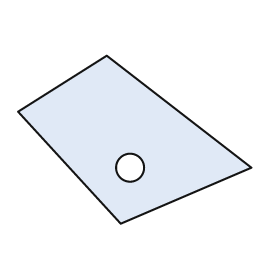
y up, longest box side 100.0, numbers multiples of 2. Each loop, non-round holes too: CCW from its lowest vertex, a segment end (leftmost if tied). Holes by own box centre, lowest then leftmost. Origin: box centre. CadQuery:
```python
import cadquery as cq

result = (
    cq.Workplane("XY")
    .moveTo(-6.0, -36.0)
    .lineTo(50.0, -12.0)
    .lineTo(-12.0, 36.0)
    .lineTo(-50.0, 12.0)
    .close()
    .moveTo(-2.0, -12.0)
    .circle(6.0)
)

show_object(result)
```